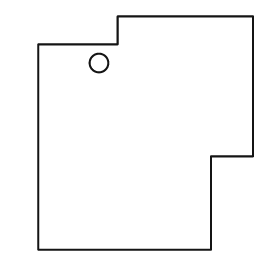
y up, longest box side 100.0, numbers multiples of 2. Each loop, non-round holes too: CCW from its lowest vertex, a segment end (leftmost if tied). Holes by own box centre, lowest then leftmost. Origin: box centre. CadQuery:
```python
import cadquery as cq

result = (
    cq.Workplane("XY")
    .moveTo(-46.0, -50.0)
    .lineTo(28.0, -50.0)
    .lineTo(28.0, -10.0)
    .lineTo(46.0, -10.0)
    .lineTo(46.0, 50.0)
    .lineTo(-12.0, 50.0)
    .lineTo(-12.0, 38.0)
    .lineTo(-46.0, 38.0)
    .close()
    .moveTo(-20.0, 30.0)
    .circle(4.0)
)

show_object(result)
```